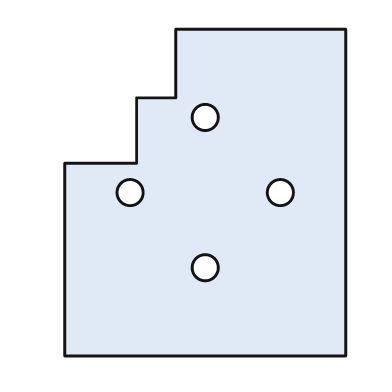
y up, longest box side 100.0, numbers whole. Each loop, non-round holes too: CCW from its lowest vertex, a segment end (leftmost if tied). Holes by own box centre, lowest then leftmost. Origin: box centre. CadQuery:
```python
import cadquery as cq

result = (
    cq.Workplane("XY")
    .moveTo(-43.0, -50.0)
    .lineTo(43.0, -50.0)
    .lineTo(43.0, 50.0)
    .lineTo(-9.0, 50.0)
    .lineTo(-9.0, 29.0)
    .lineTo(-21.0, 29.0)
    .lineTo(-21.0, 9.0)
    .lineTo(-43.0, 9.0)
    .close()
    .moveTo(0.0, -23.0)
    .circle(4.0)
    .moveTo(-23.0, 0.0)
    .circle(4.0)
    .moveTo(23.0, 0.0)
    .circle(4.0)
    .moveTo(0.0, 23.0)
    .circle(4.0)
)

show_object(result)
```